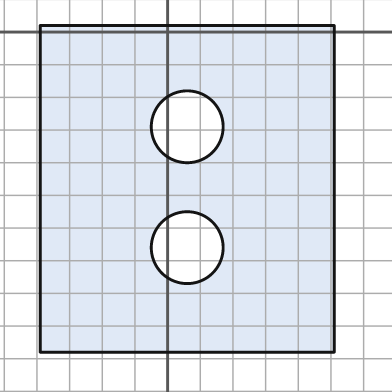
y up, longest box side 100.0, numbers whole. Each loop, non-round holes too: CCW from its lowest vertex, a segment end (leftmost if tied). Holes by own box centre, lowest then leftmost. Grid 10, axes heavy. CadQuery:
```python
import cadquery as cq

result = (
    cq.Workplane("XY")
    .moveTo(-39.0, -98.0)
    .lineTo(51.0, -98.0)
    .lineTo(51.0, 2.0)
    .lineTo(-39.0, 2.0)
    .close()
    .moveTo(6.0, -66.0)
    .circle(11.0)
    .moveTo(6.0, -29.0)
    .circle(11.0)
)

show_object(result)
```